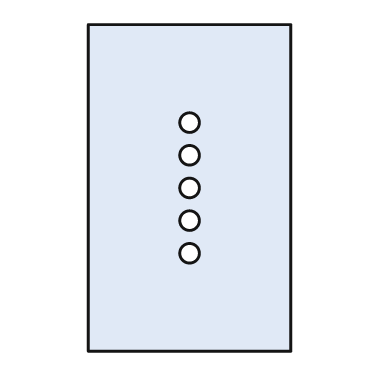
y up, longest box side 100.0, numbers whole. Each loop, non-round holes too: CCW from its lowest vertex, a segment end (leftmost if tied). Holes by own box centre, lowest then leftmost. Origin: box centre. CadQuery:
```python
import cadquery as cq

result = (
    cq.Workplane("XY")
    .moveTo(-31.0, -50.0)
    .lineTo(31.0, -50.0)
    .lineTo(31.0, 50.0)
    .lineTo(-31.0, 50.0)
    .close()
    .moveTo(0.0, -20.0)
    .circle(3.0)
    .moveTo(0.0, -10.0)
    .circle(3.0)
    .moveTo(0.0, 0.0)
    .circle(3.0)
    .moveTo(0.0, 10.0)
    .circle(3.0)
    .moveTo(0.0, 20.0)
    .circle(3.0)
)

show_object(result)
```